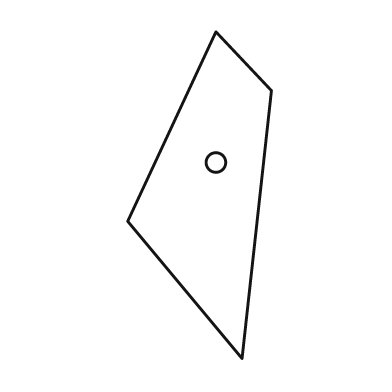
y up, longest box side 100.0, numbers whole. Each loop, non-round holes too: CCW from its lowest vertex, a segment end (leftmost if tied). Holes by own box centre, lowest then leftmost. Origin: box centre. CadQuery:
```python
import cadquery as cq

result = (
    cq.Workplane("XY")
    .moveTo(13.0, -50.0)
    .lineTo(22.0, 32.0)
    .lineTo(5.0, 50.0)
    .lineTo(-22.0, -8.0)
    .close()
    .moveTo(5.0, 10.0)
    .circle(3.0)
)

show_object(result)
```